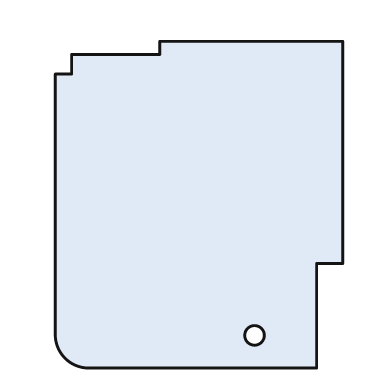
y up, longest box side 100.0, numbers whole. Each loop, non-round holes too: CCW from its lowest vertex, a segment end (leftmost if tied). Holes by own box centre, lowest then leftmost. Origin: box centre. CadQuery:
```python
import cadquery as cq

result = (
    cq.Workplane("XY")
    .moveTo(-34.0, -50.0)
    .lineTo(36.0, -50.0)
    .lineTo(36.0, -18.0)
    .lineTo(44.0, -18.0)
    .lineTo(44.0, 50.0)
    .lineTo(-12.0, 50.0)
    .lineTo(-12.0, 46.0)
    .lineTo(-39.0, 46.0)
    .lineTo(-39.0, 40.0)
    .lineTo(-44.0, 40.0)
    .lineTo(-44.0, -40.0)
    .threePointArc((-41.0, -47.0), (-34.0, -50.0))
    .close()
    .moveTo(17.0, -40.0)
    .circle(3.0)
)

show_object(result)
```